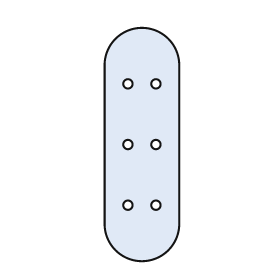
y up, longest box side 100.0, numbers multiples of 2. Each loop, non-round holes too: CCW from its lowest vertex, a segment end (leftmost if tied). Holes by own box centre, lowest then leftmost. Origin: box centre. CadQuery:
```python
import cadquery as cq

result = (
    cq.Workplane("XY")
    .moveTo(-16.0, -34.0)
    .threePointArc((0.0, -50.0), (16.0, -34.0))
    .lineTo(16.0, 34.0)
    .threePointArc((0.0, 50.0), (-16.0, 34.0))
    .close()
    .moveTo(-6.0, -26.0)
    .circle(2.0)
    .moveTo(6.0, -26.0)
    .circle(2.0)
    .moveTo(-6.0, 0.0)
    .circle(2.0)
    .moveTo(6.0, 0.0)
    .circle(2.0)
    .moveTo(-6.0, 26.0)
    .circle(2.0)
    .moveTo(6.0, 26.0)
    .circle(2.0)
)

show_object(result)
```